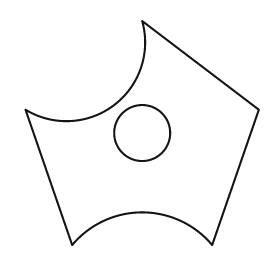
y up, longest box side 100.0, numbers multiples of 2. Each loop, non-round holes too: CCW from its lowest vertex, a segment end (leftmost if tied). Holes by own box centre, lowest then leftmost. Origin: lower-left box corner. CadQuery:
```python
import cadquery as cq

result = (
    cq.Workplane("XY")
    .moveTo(20.0, 0.0)
    .threePointArc((50.0, 14.0), (80.0, 0.0))
    .lineTo(100.0, 58.0)
    .lineTo(50.0, 96.0)
    .threePointArc((38.0, 60.0), (0.0, 58.0))
    .close()
    .moveTo(50.0, 48.0)
    .circle(12.0)
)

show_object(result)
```